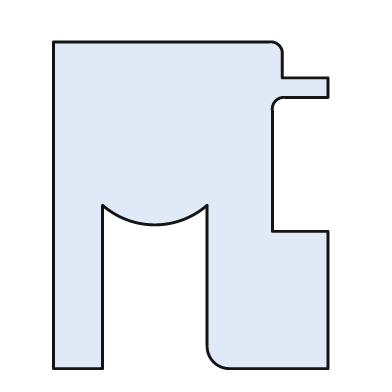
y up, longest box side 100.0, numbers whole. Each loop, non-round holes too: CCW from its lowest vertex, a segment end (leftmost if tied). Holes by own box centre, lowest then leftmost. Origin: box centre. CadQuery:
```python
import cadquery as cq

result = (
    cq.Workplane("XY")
    .moveTo(-42.0, -50.0)
    .lineTo(-27.0, -50.0)
    .lineTo(-27.0, 0.0)
    .threePointArc((-11.0, -6.0), (5.0, 0.0))
    .lineTo(5.0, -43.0)
    .threePointArc((7.0, -48.0), (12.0, -50.0))
    .lineTo(42.0, -50.0)
    .lineTo(42.0, -8.0)
    .lineTo(25.0, -8.0)
    .lineTo(25.0, 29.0)
    .threePointArc((26.0, 32.0), (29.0, 33.0))
    .lineTo(42.0, 33.0)
    .lineTo(42.0, 39.0)
    .lineTo(28.0, 39.0)
    .lineTo(28.0, 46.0)
    .threePointArc((27.0, 49.0), (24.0, 50.0))
    .lineTo(-42.0, 50.0)
    .close()
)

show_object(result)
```